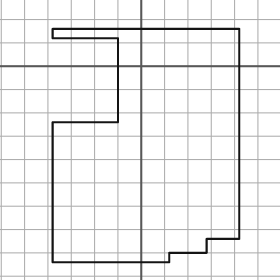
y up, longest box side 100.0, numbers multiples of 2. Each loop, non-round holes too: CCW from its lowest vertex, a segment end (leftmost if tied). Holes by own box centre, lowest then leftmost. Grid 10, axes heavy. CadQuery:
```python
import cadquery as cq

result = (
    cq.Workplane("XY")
    .moveTo(-38.0, -84.0)
    .lineTo(12.0, -84.0)
    .lineTo(12.0, -80.0)
    .lineTo(28.0, -80.0)
    .lineTo(28.0, -74.0)
    .lineTo(42.0, -74.0)
    .lineTo(42.0, 16.0)
    .lineTo(-38.0, 16.0)
    .lineTo(-38.0, 12.0)
    .lineTo(-10.0, 12.0)
    .lineTo(-10.0, -24.0)
    .lineTo(-38.0, -24.0)
    .close()
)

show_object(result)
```